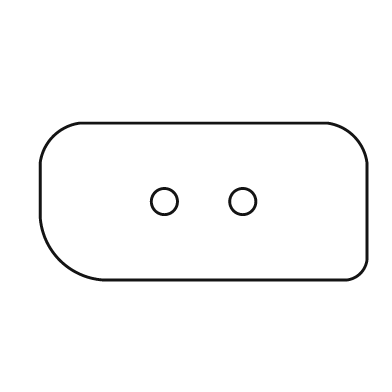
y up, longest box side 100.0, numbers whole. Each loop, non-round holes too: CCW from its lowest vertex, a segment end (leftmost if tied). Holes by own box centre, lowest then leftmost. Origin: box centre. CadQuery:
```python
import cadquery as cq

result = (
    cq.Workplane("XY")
    .moveTo(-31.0, -24.0)
    .lineTo(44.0, -24.0)
    .threePointArc((48.0, -22.0), (50.0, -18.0))
    .lineTo(50.0, 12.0)
    .threePointArc((46.0, 20.0), (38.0, 24.0))
    .lineTo(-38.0, 24.0)
    .threePointArc((-46.0, 20.0), (-50.0, 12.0))
    .lineTo(-50.0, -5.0)
    .threePointArc((-44.0, -18.0), (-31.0, -24.0))
    .close()
    .moveTo(-12.0, 0.0)
    .circle(4.0)
    .moveTo(12.0, 0.0)
    .circle(4.0)
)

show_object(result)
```